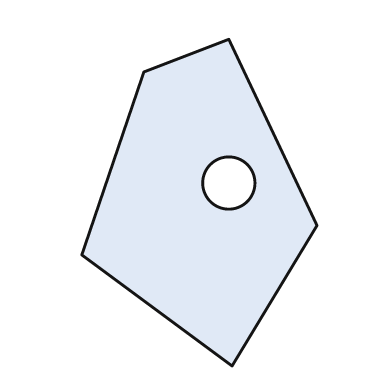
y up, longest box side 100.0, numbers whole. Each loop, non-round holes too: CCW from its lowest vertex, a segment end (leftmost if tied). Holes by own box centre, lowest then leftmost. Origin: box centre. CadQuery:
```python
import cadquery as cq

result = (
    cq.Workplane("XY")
    .moveTo(10.0, -50.0)
    .lineTo(36.0, -7.0)
    .lineTo(9.0, 50.0)
    .lineTo(-17.0, 40.0)
    .lineTo(-36.0, -16.0)
    .close()
    .moveTo(9.0, 6.0)
    .circle(8.0)
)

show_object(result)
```